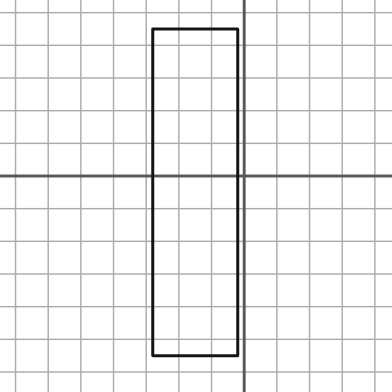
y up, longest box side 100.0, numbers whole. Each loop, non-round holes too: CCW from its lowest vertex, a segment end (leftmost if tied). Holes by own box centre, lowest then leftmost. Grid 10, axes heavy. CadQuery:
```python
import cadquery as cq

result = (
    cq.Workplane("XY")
    .moveTo(-28.0, -55.0)
    .lineTo(-2.0, -55.0)
    .lineTo(-2.0, 45.0)
    .lineTo(-28.0, 45.0)
    .close()
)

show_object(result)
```